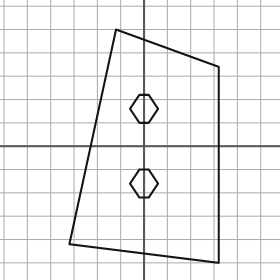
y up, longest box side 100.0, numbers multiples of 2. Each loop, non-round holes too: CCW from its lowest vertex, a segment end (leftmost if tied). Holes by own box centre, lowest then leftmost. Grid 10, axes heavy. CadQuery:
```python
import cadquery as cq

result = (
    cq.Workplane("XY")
    .moveTo(32.0, -50.0)
    .lineTo(32.0, 34.0)
    .lineTo(-12.0, 50.0)
    .lineTo(-32.0, -42.0)
    .close()
    .moveTo(-2.0, -22.0)
    .lineTo(2.0, -22.0)
    .lineTo(6.0, -16.0)
    .lineTo(2.0, -10.0)
    .lineTo(-2.0, -10.0)
    .lineTo(-6.0, -16.0)
    .close()
    .moveTo(-2.0, 10.0)
    .lineTo(2.0, 10.0)
    .lineTo(6.0, 16.0)
    .lineTo(2.0, 22.0)
    .lineTo(-2.0, 22.0)
    .lineTo(-6.0, 16.0)
    .close()
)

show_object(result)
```